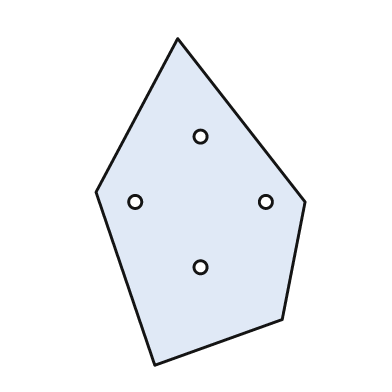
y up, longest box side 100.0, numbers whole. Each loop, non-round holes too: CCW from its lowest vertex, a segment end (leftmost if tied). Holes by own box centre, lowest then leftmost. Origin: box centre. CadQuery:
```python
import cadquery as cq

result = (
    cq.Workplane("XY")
    .moveTo(-14.0, -50.0)
    .lineTo(25.0, -36.0)
    .lineTo(32.0, 0.0)
    .lineTo(-7.0, 50.0)
    .lineTo(-32.0, 3.0)
    .close()
    .moveTo(0.0, -20.0)
    .circle(2.0)
    .moveTo(-20.0, 0.0)
    .circle(2.0)
    .moveTo(20.0, 0.0)
    .circle(2.0)
    .moveTo(0.0, 20.0)
    .circle(2.0)
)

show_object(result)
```